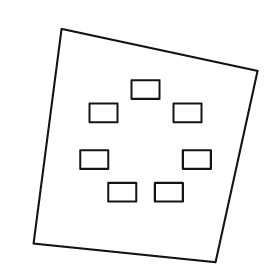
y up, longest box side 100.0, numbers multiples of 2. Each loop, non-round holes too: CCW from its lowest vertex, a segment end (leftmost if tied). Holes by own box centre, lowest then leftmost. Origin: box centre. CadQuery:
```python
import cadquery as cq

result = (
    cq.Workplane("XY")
    .moveTo(30.0, -50.0)
    .lineTo(48.0, 32.0)
    .lineTo(-36.0, 50.0)
    .lineTo(-48.0, -42.0)
    .close()
    .moveTo(-16.0, -24.0)
    .lineTo(-4.0, -24.0)
    .lineTo(-4.0, -16.0)
    .lineTo(-16.0, -16.0)
    .close()
    .moveTo(4.0, -24.0)
    .lineTo(16.0, -24.0)
    .lineTo(16.0, -16.0)
    .lineTo(4.0, -16.0)
    .close()
    .moveTo(-28.0, -10.0)
    .lineTo(-16.0, -10.0)
    .lineTo(-16.0, -2.0)
    .lineTo(-28.0, -2.0)
    .close()
    .moveTo(16.0, -10.0)
    .lineTo(28.0, -10.0)
    .lineTo(28.0, -2.0)
    .lineTo(16.0, -2.0)
    .close()
    .moveTo(-24.0, 10.0)
    .lineTo(-12.0, 10.0)
    .lineTo(-12.0, 18.0)
    .lineTo(-24.0, 18.0)
    .close()
    .moveTo(12.0, 10.0)
    .lineTo(24.0, 10.0)
    .lineTo(24.0, 18.0)
    .lineTo(12.0, 18.0)
    .close()
    .moveTo(-6.0, 20.0)
    .lineTo(6.0, 20.0)
    .lineTo(6.0, 28.0)
    .lineTo(-6.0, 28.0)
    .close()
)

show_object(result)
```